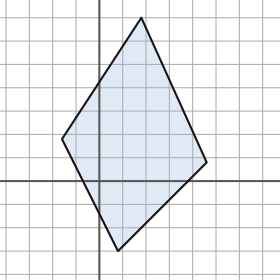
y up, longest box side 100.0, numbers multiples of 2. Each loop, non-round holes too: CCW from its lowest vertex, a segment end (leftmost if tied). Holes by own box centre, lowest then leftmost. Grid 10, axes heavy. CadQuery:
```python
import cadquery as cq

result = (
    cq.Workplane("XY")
    .moveTo(8.0, -30.0)
    .lineTo(46.0, 8.0)
    .lineTo(18.0, 70.0)
    .lineTo(-16.0, 18.0)
    .close()
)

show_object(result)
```